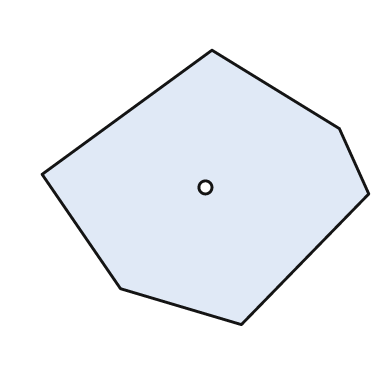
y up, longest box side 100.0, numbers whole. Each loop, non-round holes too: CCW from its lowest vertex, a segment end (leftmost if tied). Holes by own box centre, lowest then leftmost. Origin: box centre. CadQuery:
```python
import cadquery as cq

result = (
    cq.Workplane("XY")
    .moveTo(11.0, -42.0)
    .lineTo(50.0, -2.0)
    .lineTo(41.0, 18.0)
    .lineTo(2.0, 42.0)
    .lineTo(-50.0, 4.0)
    .lineTo(-26.0, -31.0)
    .close()
    .moveTo(0.0, 0.0)
    .circle(2.0)
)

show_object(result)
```